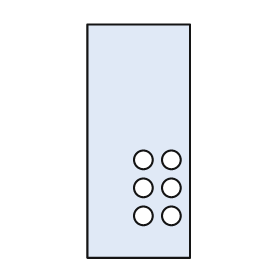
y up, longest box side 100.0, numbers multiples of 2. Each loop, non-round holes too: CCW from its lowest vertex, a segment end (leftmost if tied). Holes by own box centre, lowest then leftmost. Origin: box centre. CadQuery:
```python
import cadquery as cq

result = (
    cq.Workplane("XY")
    .moveTo(-22.0, -50.0)
    .lineTo(22.0, -50.0)
    .lineTo(22.0, 50.0)
    .lineTo(-22.0, 50.0)
    .close()
    .moveTo(2.0, -32.0)
    .circle(4.0)
    .moveTo(14.0, -32.0)
    .circle(4.0)
    .moveTo(2.0, -20.0)
    .circle(4.0)
    .moveTo(14.0, -20.0)
    .circle(4.0)
    .moveTo(2.0, -8.0)
    .circle(4.0)
    .moveTo(14.0, -8.0)
    .circle(4.0)
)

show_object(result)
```